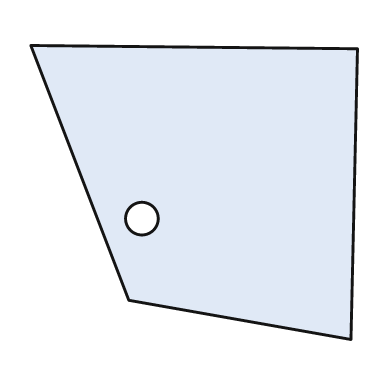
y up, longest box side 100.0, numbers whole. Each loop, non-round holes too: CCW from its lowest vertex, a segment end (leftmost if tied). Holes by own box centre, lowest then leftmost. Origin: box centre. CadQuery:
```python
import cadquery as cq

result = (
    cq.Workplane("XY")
    .moveTo(48.0, -45.0)
    .lineTo(50.0, 44.0)
    .lineTo(-50.0, 45.0)
    .lineTo(-20.0, -33.0)
    .close()
    .moveTo(-16.0, -8.0)
    .circle(5.0)
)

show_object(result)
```